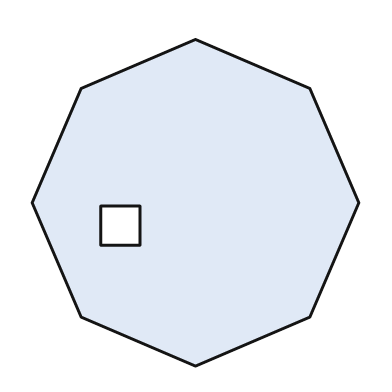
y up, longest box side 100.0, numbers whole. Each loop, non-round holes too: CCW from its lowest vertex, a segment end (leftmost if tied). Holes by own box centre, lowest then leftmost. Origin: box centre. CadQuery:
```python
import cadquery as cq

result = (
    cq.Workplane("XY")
    .moveTo(0.0, -50.0)
    .lineTo(35.0, -35.0)
    .lineTo(50.0, 0.0)
    .lineTo(35.0, 35.0)
    .lineTo(0.0, 50.0)
    .lineTo(-35.0, 35.0)
    .lineTo(-50.0, 0.0)
    .lineTo(-35.0, -35.0)
    .close()
    .moveTo(-29.0, -13.0)
    .lineTo(-17.0, -13.0)
    .lineTo(-17.0, -1.0)
    .lineTo(-29.0, -1.0)
    .close()
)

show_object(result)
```